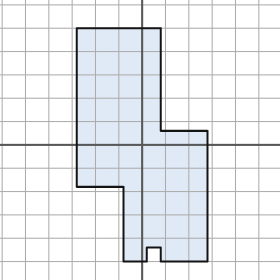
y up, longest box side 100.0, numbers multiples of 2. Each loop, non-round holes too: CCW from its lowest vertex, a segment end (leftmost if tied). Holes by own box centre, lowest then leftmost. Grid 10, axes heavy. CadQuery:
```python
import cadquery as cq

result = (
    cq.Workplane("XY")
    .moveTo(-8.0, -50.0)
    .lineTo(2.0, -50.0)
    .lineTo(2.0, -44.0)
    .lineTo(8.0, -44.0)
    .lineTo(8.0, -50.0)
    .lineTo(28.0, -50.0)
    .lineTo(28.0, 6.0)
    .lineTo(8.0, 6.0)
    .lineTo(8.0, 50.0)
    .lineTo(-28.0, 50.0)
    .lineTo(-28.0, -18.0)
    .lineTo(-8.0, -18.0)
    .close()
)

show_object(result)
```